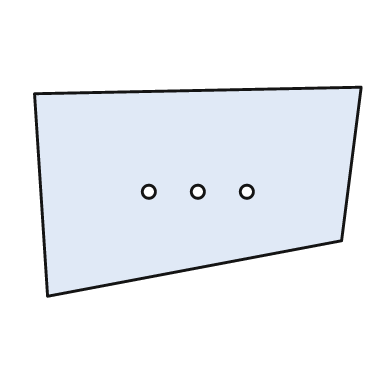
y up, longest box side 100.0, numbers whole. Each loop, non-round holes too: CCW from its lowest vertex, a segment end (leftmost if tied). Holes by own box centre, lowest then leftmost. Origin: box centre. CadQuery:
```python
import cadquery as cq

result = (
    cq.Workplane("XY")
    .moveTo(-46.0, -32.0)
    .lineTo(44.0, -15.0)
    .lineTo(50.0, 32.0)
    .lineTo(-50.0, 30.0)
    .close()
    .moveTo(-15.0, 0.0)
    .circle(2.0)
    .moveTo(0.0, 0.0)
    .circle(2.0)
    .moveTo(15.0, 0.0)
    .circle(2.0)
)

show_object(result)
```